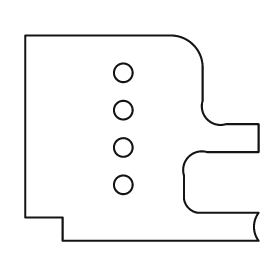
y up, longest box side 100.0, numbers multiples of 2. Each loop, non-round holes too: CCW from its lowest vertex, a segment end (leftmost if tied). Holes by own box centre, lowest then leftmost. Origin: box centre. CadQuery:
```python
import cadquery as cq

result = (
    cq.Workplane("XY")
    .moveTo(-34.0, -44.0)
    .lineTo(50.0, -44.0)
    .threePointArc((48.0, -38.0), (50.0, -32.0))
    .lineTo(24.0, -32.0)
    .threePointArc((20.0, -30.0), (18.0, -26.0))
    .lineTo(18.0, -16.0)
    .threePointArc((20.0, -8.0), (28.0, -6.0))
    .lineTo(50.0, -6.0)
    .lineTo(50.0, 6.0)
    .lineTo(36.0, 6.0)
    .threePointArc((28.0, 8.0), (26.0, 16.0))
    .lineTo(26.0, 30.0)
    .threePointArc((22.0, 40.0), (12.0, 44.0))
    .lineTo(-50.0, 44.0)
    .lineTo(-50.0, -34.0)
    .lineTo(-34.0, -34.0)
    .close()
    .moveTo(-8.0, -20.0)
    .circle(4.0)
    .moveTo(-8.0, -4.0)
    .circle(4.0)
    .moveTo(-8.0, 12.0)
    .circle(4.0)
    .moveTo(-8.0, 28.0)
    .circle(4.0)
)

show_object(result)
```